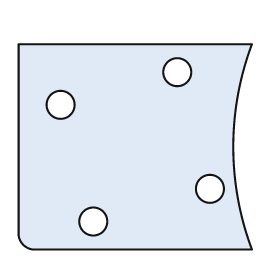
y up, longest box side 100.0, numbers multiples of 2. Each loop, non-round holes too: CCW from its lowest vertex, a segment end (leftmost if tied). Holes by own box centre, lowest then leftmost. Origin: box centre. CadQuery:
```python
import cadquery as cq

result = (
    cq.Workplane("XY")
    .moveTo(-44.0, -44.0)
    .lineTo(50.0, -44.0)
    .threePointArc((42.0, 0.0), (50.0, 44.0))
    .lineTo(-50.0, 44.0)
    .lineTo(-50.0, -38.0)
    .threePointArc((-48.0, -42.0), (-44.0, -44.0))
    .close()
    .moveTo(-18.0, -32.0)
    .circle(6.0)
    .moveTo(32.0, -18.0)
    .circle(6.0)
    .moveTo(-32.0, 18.0)
    .circle(6.0)
    .moveTo(18.0, 32.0)
    .circle(6.0)
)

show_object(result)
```